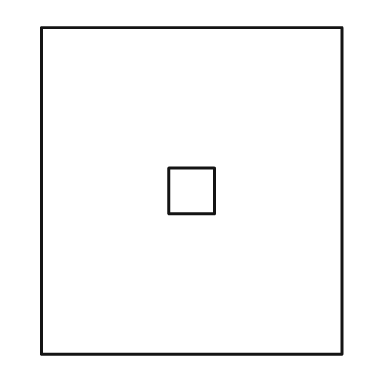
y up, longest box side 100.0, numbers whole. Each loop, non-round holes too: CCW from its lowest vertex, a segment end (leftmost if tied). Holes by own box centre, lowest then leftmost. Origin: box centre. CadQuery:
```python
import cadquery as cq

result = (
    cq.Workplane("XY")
    .moveTo(-46.0, -50.0)
    .lineTo(46.0, -50.0)
    .lineTo(46.0, 50.0)
    .lineTo(-46.0, 50.0)
    .close()
    .moveTo(-7.0, -7.0)
    .lineTo(7.0, -7.0)
    .lineTo(7.0, 7.0)
    .lineTo(-7.0, 7.0)
    .close()
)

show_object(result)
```